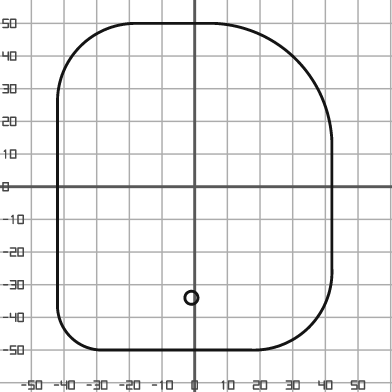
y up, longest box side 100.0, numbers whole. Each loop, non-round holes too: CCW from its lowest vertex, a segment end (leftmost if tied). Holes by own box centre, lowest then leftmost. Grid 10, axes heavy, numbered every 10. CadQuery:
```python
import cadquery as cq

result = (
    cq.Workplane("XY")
    .moveTo(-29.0, -50.0)
    .lineTo(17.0, -50.0)
    .threePointArc((35.0, -43.0), (42.0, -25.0))
    .lineTo(42.0, 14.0)
    .threePointArc((31.0, 39.0), (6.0, 50.0))
    .lineTo(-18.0, 50.0)
    .threePointArc((-35.0, 43.0), (-42.0, 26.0))
    .lineTo(-42.0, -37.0)
    .threePointArc((-38.0, -46.0), (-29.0, -50.0))
    .close()
    .moveTo(-1.0, -34.0)
    .circle(2.0)
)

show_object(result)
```